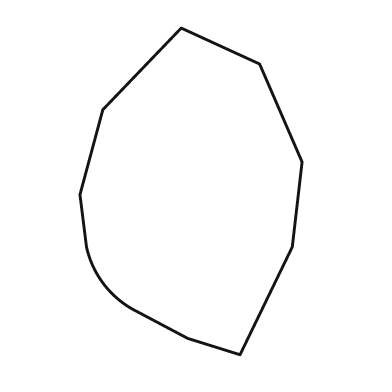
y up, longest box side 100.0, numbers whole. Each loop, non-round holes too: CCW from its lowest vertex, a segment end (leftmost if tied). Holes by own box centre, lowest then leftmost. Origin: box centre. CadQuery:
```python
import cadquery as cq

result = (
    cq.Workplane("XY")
    .moveTo(15.0, -50.0)
    .lineTo(31.0, -17.0)
    .lineTo(34.0, 9.0)
    .lineTo(21.0, 39.0)
    .lineTo(-3.0, 50.0)
    .lineTo(-27.0, 25.0)
    .lineTo(-34.0, -1.0)
    .lineTo(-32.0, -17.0)
    .threePointArc((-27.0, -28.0), (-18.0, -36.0))
    .lineTo(-1.0, -45.0)
    .close()
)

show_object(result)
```